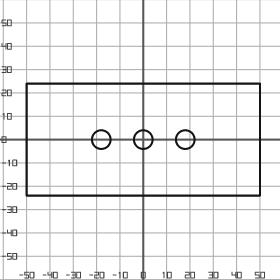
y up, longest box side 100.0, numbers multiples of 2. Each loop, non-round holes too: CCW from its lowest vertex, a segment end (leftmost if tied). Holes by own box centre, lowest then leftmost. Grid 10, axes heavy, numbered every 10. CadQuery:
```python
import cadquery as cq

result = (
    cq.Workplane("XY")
    .moveTo(-50.0, -24.0)
    .lineTo(50.0, -24.0)
    .lineTo(50.0, 24.0)
    .lineTo(-50.0, 24.0)
    .close()
    .moveTo(-18.0, 0.0)
    .circle(4.0)
    .moveTo(0.0, 0.0)
    .circle(4.0)
    .moveTo(18.0, 0.0)
    .circle(4.0)
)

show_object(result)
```